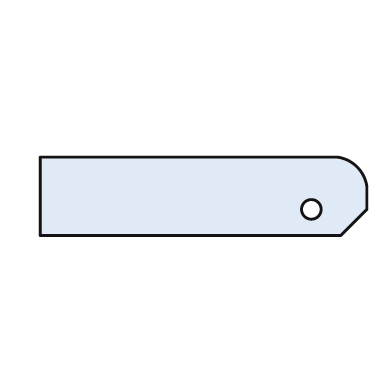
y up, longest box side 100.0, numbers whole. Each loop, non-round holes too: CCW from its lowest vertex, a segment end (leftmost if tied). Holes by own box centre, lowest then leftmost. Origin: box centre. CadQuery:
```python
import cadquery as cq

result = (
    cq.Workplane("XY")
    .moveTo(-50.0, -12.0)
    .lineTo(42.0, -12.0)
    .lineTo(50.0, -4.0)
    .lineTo(50.0, 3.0)
    .threePointArc((47.0, 9.0), (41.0, 12.0))
    .lineTo(-50.0, 12.0)
    .close()
    .moveTo(33.0, -4.0)
    .circle(3.0)
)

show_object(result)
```